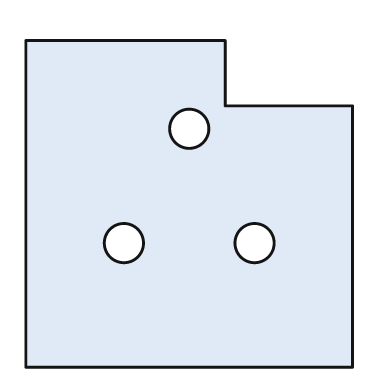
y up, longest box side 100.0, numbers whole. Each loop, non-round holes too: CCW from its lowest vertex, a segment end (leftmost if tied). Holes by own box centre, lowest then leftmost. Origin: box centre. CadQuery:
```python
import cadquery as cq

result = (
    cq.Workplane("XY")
    .moveTo(-50.0, -50.0)
    .lineTo(50.0, -50.0)
    .lineTo(50.0, 30.0)
    .lineTo(11.0, 30.0)
    .lineTo(11.0, 50.0)
    .lineTo(-50.0, 50.0)
    .close()
    .moveTo(-20.0, -12.0)
    .circle(6.0)
    .moveTo(20.0, -12.0)
    .circle(6.0)
    .moveTo(0.0, 23.0)
    .circle(6.0)
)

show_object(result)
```